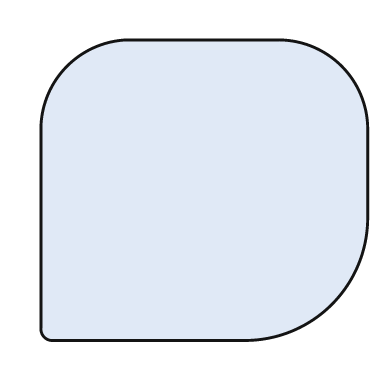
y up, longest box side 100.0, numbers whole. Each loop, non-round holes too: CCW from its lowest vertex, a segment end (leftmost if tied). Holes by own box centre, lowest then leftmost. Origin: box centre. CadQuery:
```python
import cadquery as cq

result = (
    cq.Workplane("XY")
    .moveTo(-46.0, -46.0)
    .lineTo(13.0, -46.0)
    .threePointArc((39.0, -35.0), (50.0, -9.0))
    .lineTo(50.0, 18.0)
    .threePointArc((42.0, 38.0), (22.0, 46.0))
    .lineTo(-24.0, 46.0)
    .threePointArc((-42.0, 38.0), (-50.0, 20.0))
    .lineTo(-50.0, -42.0)
    .threePointArc((-49.0, -45.0), (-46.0, -46.0))
    .close()
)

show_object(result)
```